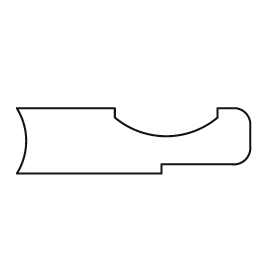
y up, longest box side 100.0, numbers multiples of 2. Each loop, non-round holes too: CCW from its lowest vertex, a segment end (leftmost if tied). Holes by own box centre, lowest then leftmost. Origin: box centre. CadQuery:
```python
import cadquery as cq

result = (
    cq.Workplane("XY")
    .moveTo(-50.0, -14.0)
    .lineTo(12.0, -14.0)
    .lineTo(12.0, -10.0)
    .lineTo(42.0, -10.0)
    .threePointArc((48.0, -8.0), (50.0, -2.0))
    .lineTo(50.0, 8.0)
    .threePointArc((48.0, 12.0), (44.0, 14.0))
    .lineTo(36.0, 14.0)
    .lineTo(36.0, 10.0)
    .threePointArc((14.0, 2.0), (-8.0, 10.0))
    .lineTo(-8.0, 14.0)
    .lineTo(-50.0, 14.0)
    .threePointArc((-46.0, 0.0), (-50.0, -14.0))
    .close()
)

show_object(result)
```